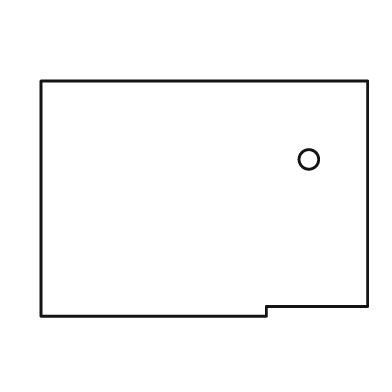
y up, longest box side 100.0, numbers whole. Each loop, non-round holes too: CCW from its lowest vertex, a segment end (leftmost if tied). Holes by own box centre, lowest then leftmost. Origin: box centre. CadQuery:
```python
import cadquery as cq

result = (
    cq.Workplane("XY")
    .moveTo(-50.0, -36.0)
    .lineTo(19.0, -36.0)
    .lineTo(19.0, -33.0)
    .lineTo(50.0, -33.0)
    .lineTo(50.0, 36.0)
    .lineTo(-50.0, 36.0)
    .close()
    .moveTo(32.0, 12.0)
    .circle(3.0)
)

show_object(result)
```